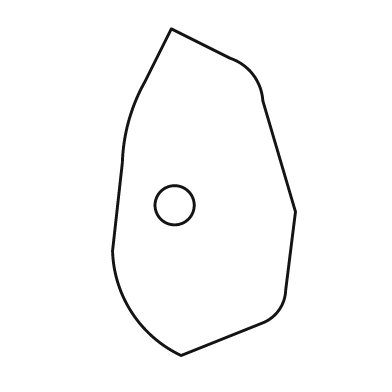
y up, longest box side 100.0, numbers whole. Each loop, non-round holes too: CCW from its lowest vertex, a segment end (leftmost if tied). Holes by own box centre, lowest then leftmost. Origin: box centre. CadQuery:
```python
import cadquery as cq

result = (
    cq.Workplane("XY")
    .moveTo(-7.0, -50.0)
    .lineTo(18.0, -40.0)
    .threePointArc((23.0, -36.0), (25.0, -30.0))
    .lineTo(28.0, -6.0)
    .lineTo(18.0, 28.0)
    .threePointArc((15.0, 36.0), (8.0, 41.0))
    .lineTo(-10.0, 50.0)
    .lineTo(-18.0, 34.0)
    .threePointArc((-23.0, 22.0), (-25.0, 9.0))
    .lineTo(-28.0, -18.0)
    .threePointArc((-22.0, -37.0), (-7.0, -50.0))
    .close()
    .moveTo(-9.0, -4.0)
    .circle(6.0)
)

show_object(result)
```